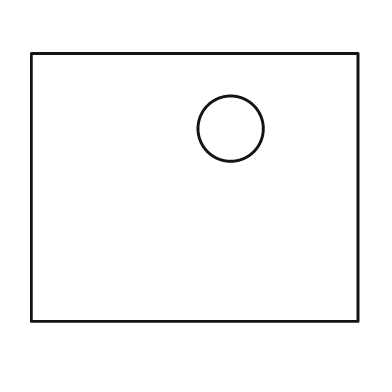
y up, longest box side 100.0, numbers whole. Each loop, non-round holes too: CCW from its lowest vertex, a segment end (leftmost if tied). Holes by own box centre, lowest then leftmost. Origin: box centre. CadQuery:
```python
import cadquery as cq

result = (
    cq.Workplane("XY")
    .moveTo(-50.0, -41.0)
    .lineTo(50.0, -41.0)
    .lineTo(50.0, 41.0)
    .lineTo(-50.0, 41.0)
    .close()
    .moveTo(11.0, 18.0)
    .circle(10.0)
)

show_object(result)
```